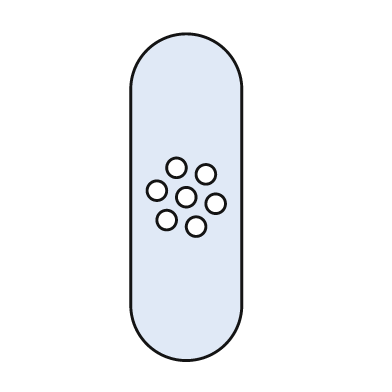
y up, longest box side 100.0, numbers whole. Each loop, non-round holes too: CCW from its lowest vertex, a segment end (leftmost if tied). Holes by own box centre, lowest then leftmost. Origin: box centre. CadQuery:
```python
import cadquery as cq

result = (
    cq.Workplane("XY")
    .moveTo(-17.0, -33.0)
    .threePointArc((0.0, -50.0), (17.0, -33.0))
    .lineTo(17.0, 33.0)
    .threePointArc((0.0, 50.0), (-17.0, 33.0))
    .close()
    .moveTo(3.0, -9.0)
    .circle(3.0)
    .moveTo(-6.0, -7.0)
    .circle(3.0)
    .moveTo(9.0, -2.0)
    .circle(3.0)
    .moveTo(0.0, 0.0)
    .circle(3.0)
    .moveTo(-9.0, 2.0)
    .circle(3.0)
    .moveTo(6.0, 7.0)
    .circle(3.0)
    .moveTo(-3.0, 9.0)
    .circle(3.0)
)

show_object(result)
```